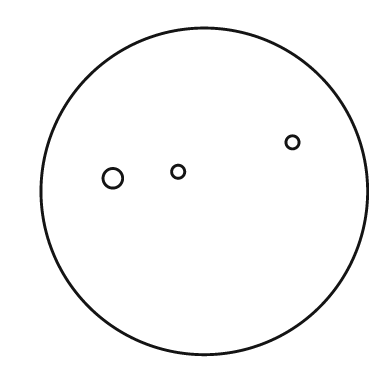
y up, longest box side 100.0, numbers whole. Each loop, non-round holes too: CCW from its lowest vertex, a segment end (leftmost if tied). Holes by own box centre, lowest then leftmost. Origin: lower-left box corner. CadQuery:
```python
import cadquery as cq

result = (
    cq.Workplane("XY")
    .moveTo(50.0, 50.0)
    .circle(50.0)
    .moveTo(22.0, 54.0)
    .circle(3.0)
    .moveTo(42.0, 56.0)
    .circle(2.0)
    .moveTo(77.0, 65.0)
    .circle(2.0)
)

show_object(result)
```